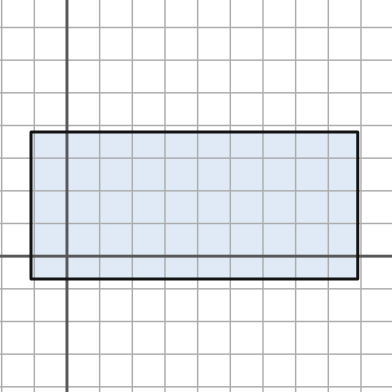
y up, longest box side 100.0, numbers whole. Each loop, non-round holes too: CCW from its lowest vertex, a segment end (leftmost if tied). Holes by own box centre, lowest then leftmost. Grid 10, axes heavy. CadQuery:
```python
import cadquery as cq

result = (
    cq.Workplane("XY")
    .moveTo(-11.0, -7.0)
    .lineTo(89.0, -7.0)
    .lineTo(89.0, 38.0)
    .lineTo(-11.0, 38.0)
    .close()
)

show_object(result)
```